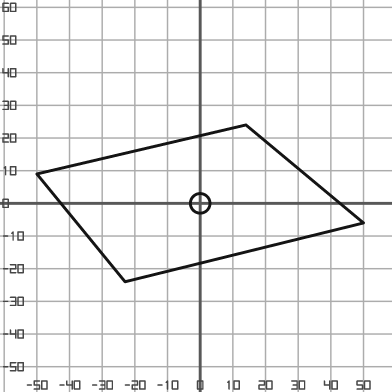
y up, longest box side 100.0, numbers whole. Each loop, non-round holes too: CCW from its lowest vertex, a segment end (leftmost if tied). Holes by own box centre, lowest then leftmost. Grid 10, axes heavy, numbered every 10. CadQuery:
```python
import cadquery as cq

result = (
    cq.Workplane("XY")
    .moveTo(-23.0, -24.0)
    .lineTo(50.0, -6.0)
    .lineTo(14.0, 24.0)
    .lineTo(-50.0, 9.0)
    .close()
    .moveTo(0.0, 0.0)
    .circle(3.0)
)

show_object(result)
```